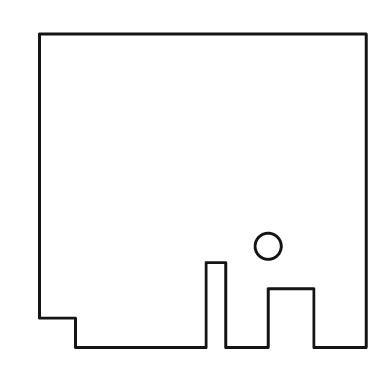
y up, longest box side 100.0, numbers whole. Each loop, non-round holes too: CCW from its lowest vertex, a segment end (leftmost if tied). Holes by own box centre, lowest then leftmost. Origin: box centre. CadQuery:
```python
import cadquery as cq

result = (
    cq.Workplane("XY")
    .moveTo(-39.0, -48.0)
    .lineTo(1.0, -48.0)
    .lineTo(1.0, -22.0)
    .lineTo(7.0, -22.0)
    .lineTo(7.0, -48.0)
    .lineTo(20.0, -48.0)
    .lineTo(20.0, -30.0)
    .lineTo(34.0, -30.0)
    .lineTo(34.0, -48.0)
    .lineTo(50.0, -48.0)
    .lineTo(50.0, 48.0)
    .lineTo(-50.0, 48.0)
    .lineTo(-50.0, -39.0)
    .lineTo(-39.0, -39.0)
    .close()
    .moveTo(20.0, -17.0)
    .circle(4.0)
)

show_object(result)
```